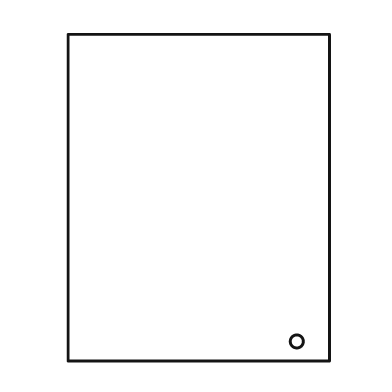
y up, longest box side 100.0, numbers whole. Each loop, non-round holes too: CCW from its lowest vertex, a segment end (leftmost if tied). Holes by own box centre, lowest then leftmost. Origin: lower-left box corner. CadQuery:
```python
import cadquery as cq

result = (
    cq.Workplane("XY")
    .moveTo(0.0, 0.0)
    .lineTo(80.0, 0.0)
    .lineTo(80.0, 100.0)
    .lineTo(0.0, 100.0)
    .close()
    .moveTo(70.0, 6.0)
    .circle(2.0)
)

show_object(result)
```